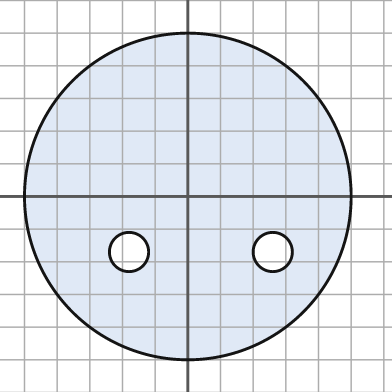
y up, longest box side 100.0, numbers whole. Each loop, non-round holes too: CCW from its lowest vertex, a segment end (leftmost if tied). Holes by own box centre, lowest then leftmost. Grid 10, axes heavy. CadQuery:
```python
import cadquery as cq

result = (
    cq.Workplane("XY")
    .moveTo(0.0, 0.0)
    .circle(50.0)
    .moveTo(-18.0, -17.0)
    .circle(6.0)
    .moveTo(26.0, -17.0)
    .circle(6.0)
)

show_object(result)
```